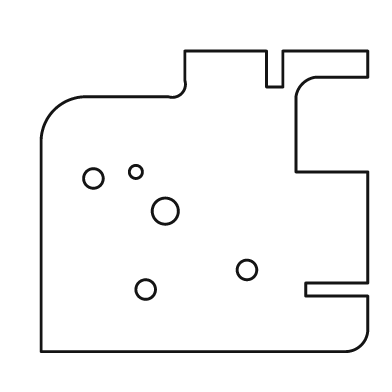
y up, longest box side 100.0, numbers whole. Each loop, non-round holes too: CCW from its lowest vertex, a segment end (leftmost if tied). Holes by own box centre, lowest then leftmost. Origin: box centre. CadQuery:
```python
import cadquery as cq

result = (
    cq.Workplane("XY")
    .moveTo(-50.0, -46.0)
    .lineTo(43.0, -46.0)
    .threePointArc((48.0, -44.0), (50.0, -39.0))
    .lineTo(50.0, -29.0)
    .lineTo(31.0, -29.0)
    .lineTo(31.0, -25.0)
    .lineTo(50.0, -25.0)
    .lineTo(50.0, 9.0)
    .lineTo(28.0, 9.0)
    .lineTo(28.0, 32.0)
    .threePointArc((30.0, 36.0), (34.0, 38.0))
    .lineTo(50.0, 38.0)
    .lineTo(50.0, 46.0)
    .lineTo(24.0, 46.0)
    .lineTo(24.0, 35.0)
    .lineTo(19.0, 35.0)
    .lineTo(19.0, 46.0)
    .lineTo(-6.0, 46.0)
    .lineTo(-6.0, 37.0)
    .threePointArc((-7.0, 33.0), (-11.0, 32.0))
    .lineTo(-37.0, 32.0)
    .threePointArc((-46.0, 28.0), (-50.0, 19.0))
    .close()
    .moveTo(-18.0, -27.0)
    .circle(3.0)
    .moveTo(13.0, -21.0)
    .circle(3.0)
    .moveTo(-12.0, -3.0)
    .circle(4.0)
    .moveTo(-34.0, 7.0)
    .circle(3.0)
    .moveTo(-21.0, 9.0)
    .circle(2.0)
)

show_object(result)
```